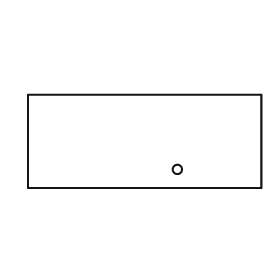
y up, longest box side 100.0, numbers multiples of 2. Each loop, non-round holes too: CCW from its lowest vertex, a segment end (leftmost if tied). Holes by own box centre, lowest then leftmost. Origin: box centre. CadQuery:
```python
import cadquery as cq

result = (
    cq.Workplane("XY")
    .moveTo(-50.0, -20.0)
    .lineTo(50.0, -20.0)
    .lineTo(50.0, 20.0)
    .lineTo(-50.0, 20.0)
    .close()
    .moveTo(14.0, -12.0)
    .circle(2.0)
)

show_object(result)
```